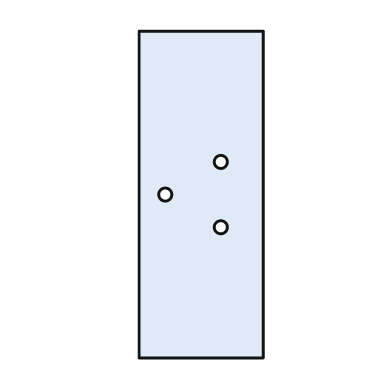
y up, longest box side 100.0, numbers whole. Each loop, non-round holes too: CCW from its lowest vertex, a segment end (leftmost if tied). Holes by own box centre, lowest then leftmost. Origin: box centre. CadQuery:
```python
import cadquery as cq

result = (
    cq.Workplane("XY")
    .moveTo(-19.0, -50.0)
    .lineTo(19.0, -50.0)
    .lineTo(19.0, 50.0)
    .lineTo(-19.0, 50.0)
    .close()
    .moveTo(6.0, -10.0)
    .circle(2.0)
    .moveTo(-11.0, 0.0)
    .circle(2.0)
    .moveTo(6.0, 10.0)
    .circle(2.0)
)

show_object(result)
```